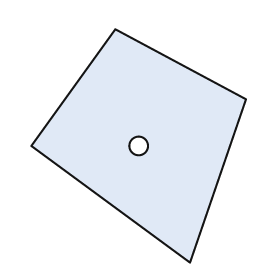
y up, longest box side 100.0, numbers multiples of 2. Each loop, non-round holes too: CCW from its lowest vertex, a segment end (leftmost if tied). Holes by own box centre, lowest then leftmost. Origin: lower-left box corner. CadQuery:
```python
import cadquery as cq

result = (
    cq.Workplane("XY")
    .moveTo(68.0, 0.0)
    .lineTo(92.0, 70.0)
    .lineTo(36.0, 100.0)
    .lineTo(0.0, 50.0)
    .close()
    .moveTo(46.0, 50.0)
    .circle(4.0)
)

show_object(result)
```